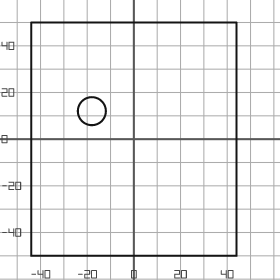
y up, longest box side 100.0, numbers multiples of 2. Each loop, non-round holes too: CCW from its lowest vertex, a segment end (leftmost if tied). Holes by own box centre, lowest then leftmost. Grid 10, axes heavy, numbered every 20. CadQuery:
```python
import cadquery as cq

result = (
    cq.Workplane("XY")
    .moveTo(-44.0, -50.0)
    .lineTo(44.0, -50.0)
    .lineTo(44.0, 50.0)
    .lineTo(-44.0, 50.0)
    .close()
    .moveTo(-18.0, 12.0)
    .circle(6.0)
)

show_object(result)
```